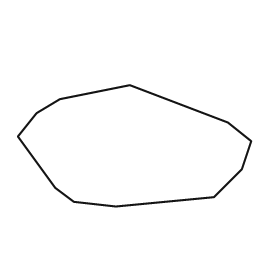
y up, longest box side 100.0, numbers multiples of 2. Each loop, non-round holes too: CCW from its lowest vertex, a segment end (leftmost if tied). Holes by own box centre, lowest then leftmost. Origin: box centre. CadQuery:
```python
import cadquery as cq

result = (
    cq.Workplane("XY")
    .moveTo(-8.0, -26.0)
    .lineTo(34.0, -22.0)
    .lineTo(46.0, -10.0)
    .lineTo(50.0, 2.0)
    .lineTo(40.0, 10.0)
    .lineTo(-2.0, 26.0)
    .lineTo(-32.0, 20.0)
    .lineTo(-42.0, 14.0)
    .lineTo(-50.0, 4.0)
    .lineTo(-34.0, -18.0)
    .lineTo(-26.0, -24.0)
    .close()
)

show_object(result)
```